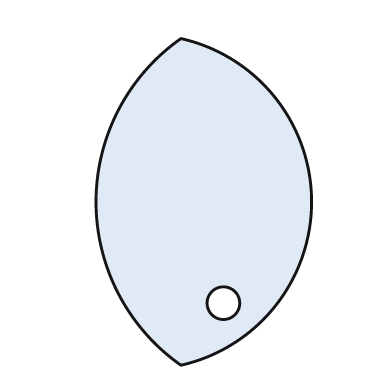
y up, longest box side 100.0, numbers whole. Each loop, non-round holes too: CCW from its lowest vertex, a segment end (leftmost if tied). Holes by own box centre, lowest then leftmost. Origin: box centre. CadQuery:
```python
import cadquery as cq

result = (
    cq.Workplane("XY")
    .moveTo(-7.0, -50.0)
    .threePointArc((33.0, 0.0), (-7.0, 50.0))
    .threePointArc((-33.0, 0.0), (-7.0, -50.0))
    .close()
    .moveTo(6.0, -31.0)
    .circle(5.0)
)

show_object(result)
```